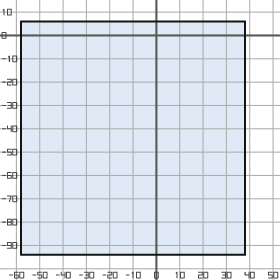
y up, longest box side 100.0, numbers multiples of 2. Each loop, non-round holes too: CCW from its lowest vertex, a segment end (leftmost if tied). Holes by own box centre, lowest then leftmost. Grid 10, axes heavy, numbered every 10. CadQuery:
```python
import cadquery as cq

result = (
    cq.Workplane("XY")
    .moveTo(-58.0, -94.0)
    .lineTo(38.0, -94.0)
    .lineTo(38.0, 6.0)
    .lineTo(-58.0, 6.0)
    .close()
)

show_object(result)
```